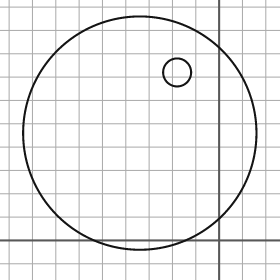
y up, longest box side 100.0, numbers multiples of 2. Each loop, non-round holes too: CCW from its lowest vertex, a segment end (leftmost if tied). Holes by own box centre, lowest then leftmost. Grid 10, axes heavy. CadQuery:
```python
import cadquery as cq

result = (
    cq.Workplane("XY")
    .moveTo(-34.0, 46.0)
    .circle(50.0)
    .moveTo(-18.0, 72.0)
    .circle(6.0)
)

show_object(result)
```